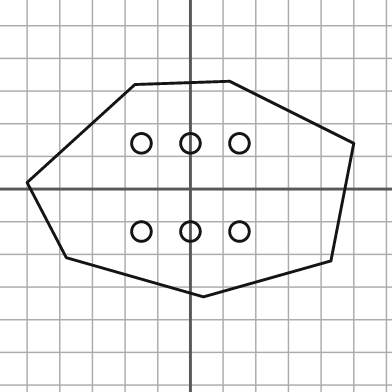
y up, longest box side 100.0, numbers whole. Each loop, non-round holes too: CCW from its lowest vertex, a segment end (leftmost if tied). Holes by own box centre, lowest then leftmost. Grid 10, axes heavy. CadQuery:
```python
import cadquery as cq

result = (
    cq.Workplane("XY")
    .moveTo(4.0, -33.0)
    .lineTo(43.0, -22.0)
    .lineTo(50.0, 14.0)
    .lineTo(12.0, 33.0)
    .lineTo(-17.0, 32.0)
    .lineTo(-50.0, 2.0)
    .lineTo(-38.0, -21.0)
    .close()
    .moveTo(-15.0, -13.0)
    .circle(3.0)
    .moveTo(0.0, -13.0)
    .circle(3.0)
    .moveTo(15.0, -13.0)
    .circle(3.0)
    .moveTo(-15.0, 14.0)
    .circle(3.0)
    .moveTo(0.0, 14.0)
    .circle(3.0)
    .moveTo(15.0, 14.0)
    .circle(3.0)
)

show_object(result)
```